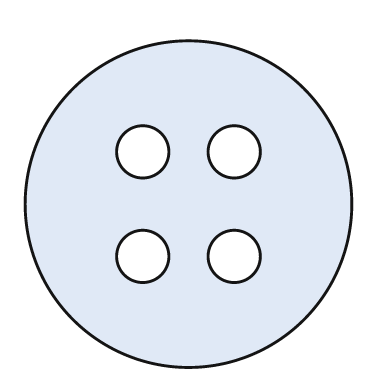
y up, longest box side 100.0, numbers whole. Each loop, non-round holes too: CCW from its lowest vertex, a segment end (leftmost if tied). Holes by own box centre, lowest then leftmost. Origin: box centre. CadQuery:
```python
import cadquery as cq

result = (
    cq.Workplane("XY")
    .moveTo(0.0, 0.0)
    .circle(50.0)
    .moveTo(-14.0, -16.0)
    .circle(8.0)
    .moveTo(14.0, -16.0)
    .circle(8.0)
    .moveTo(-14.0, 16.0)
    .circle(8.0)
    .moveTo(14.0, 16.0)
    .circle(8.0)
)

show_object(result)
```